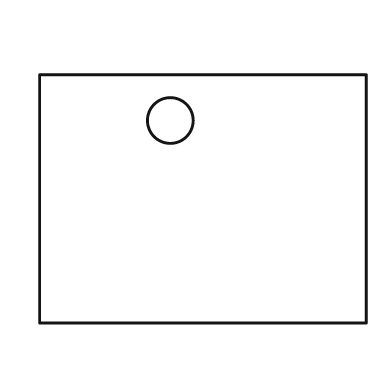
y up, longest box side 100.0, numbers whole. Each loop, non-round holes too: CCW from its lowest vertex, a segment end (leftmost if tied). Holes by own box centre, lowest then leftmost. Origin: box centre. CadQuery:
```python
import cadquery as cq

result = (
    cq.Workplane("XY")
    .moveTo(-50.0, -38.0)
    .lineTo(50.0, -38.0)
    .lineTo(50.0, 38.0)
    .lineTo(-50.0, 38.0)
    .close()
    .moveTo(-10.0, 24.0)
    .circle(7.0)
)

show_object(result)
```